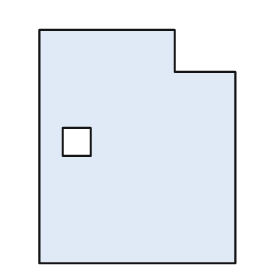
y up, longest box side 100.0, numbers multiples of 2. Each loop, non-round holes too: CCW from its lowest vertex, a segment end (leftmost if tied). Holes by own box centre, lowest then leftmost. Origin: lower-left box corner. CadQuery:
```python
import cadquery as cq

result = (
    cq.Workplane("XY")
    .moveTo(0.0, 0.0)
    .lineTo(84.0, 0.0)
    .lineTo(84.0, 82.0)
    .lineTo(58.0, 82.0)
    .lineTo(58.0, 100.0)
    .lineTo(0.0, 100.0)
    .close()
    .moveTo(10.0, 46.0)
    .lineTo(22.0, 46.0)
    .lineTo(22.0, 58.0)
    .lineTo(10.0, 58.0)
    .close()
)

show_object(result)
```